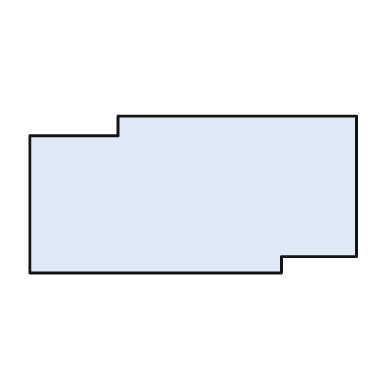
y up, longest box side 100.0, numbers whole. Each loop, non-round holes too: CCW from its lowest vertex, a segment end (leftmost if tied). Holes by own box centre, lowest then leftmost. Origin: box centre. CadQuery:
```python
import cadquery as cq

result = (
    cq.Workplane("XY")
    .moveTo(-50.0, -24.0)
    .lineTo(27.0, -24.0)
    .lineTo(27.0, -19.0)
    .lineTo(50.0, -19.0)
    .lineTo(50.0, 24.0)
    .lineTo(-23.0, 24.0)
    .lineTo(-23.0, 18.0)
    .lineTo(-50.0, 18.0)
    .close()
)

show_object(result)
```